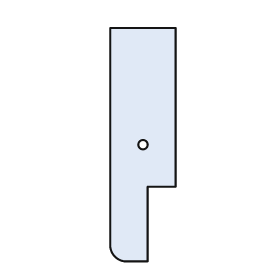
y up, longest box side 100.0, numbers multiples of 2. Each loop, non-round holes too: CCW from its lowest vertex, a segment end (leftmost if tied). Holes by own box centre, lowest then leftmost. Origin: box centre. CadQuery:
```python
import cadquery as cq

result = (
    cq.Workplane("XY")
    .moveTo(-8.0, -50.0)
    .lineTo(2.0, -50.0)
    .lineTo(2.0, -18.0)
    .lineTo(14.0, -18.0)
    .lineTo(14.0, 50.0)
    .lineTo(-14.0, 50.0)
    .lineTo(-14.0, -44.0)
    .threePointArc((-12.0, -48.0), (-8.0, -50.0))
    .close()
    .moveTo(0.0, 0.0)
    .circle(2.0)
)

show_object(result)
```